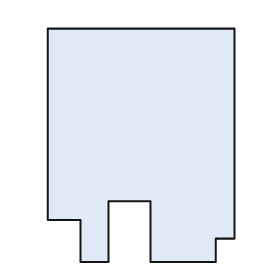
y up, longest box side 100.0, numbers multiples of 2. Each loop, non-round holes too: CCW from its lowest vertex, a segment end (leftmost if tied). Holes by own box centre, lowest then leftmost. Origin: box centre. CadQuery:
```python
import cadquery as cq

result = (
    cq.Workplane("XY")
    .moveTo(-26.0, -50.0)
    .lineTo(-14.0, -50.0)
    .lineTo(-14.0, -24.0)
    .lineTo(4.0, -24.0)
    .lineTo(4.0, -50.0)
    .lineTo(32.0, -50.0)
    .lineTo(32.0, -40.0)
    .lineTo(40.0, -40.0)
    .lineTo(40.0, 50.0)
    .lineTo(-40.0, 50.0)
    .lineTo(-40.0, -32.0)
    .lineTo(-26.0, -32.0)
    .close()
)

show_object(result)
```